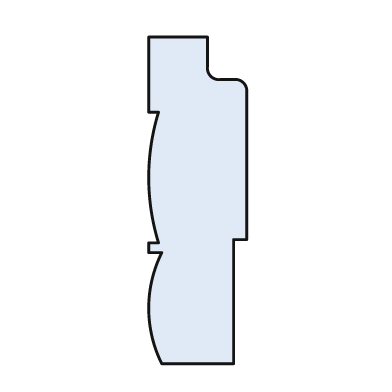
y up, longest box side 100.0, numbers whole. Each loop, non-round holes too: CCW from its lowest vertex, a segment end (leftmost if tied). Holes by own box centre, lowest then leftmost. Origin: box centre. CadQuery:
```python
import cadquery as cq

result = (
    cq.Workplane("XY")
    .moveTo(-11.0, -50.0)
    .lineTo(11.0, -50.0)
    .lineTo(11.0, -12.0)
    .lineTo(15.0, -12.0)
    .lineTo(15.0, 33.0)
    .threePointArc((14.0, 36.0), (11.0, 37.0))
    .lineTo(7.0, 37.0)
    .threePointArc((4.0, 38.0), (3.0, 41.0))
    .lineTo(3.0, 50.0)
    .lineTo(-15.0, 50.0)
    .lineTo(-15.0, 27.0)
    .lineTo(-12.0, 27.0)
    .threePointArc((-15.0, 7.0), (-12.0, -13.0))
    .lineTo(-15.0, -13.0)
    .lineTo(-15.0, -16.0)
    .lineTo(-11.0, -16.0)
    .threePointArc((-15.0, -33.0), (-11.0, -50.0))
    .close()
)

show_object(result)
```